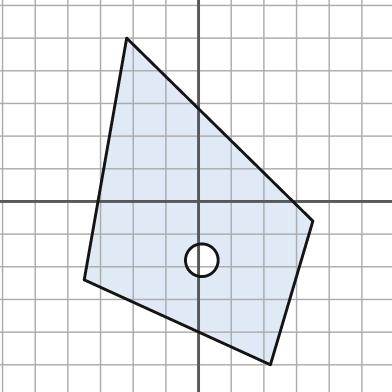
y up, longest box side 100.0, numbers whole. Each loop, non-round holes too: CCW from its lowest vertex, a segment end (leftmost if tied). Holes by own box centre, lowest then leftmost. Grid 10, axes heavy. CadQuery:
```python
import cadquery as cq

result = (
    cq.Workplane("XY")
    .moveTo(22.0, -50.0)
    .lineTo(35.0, -6.0)
    .lineTo(-22.0, 50.0)
    .lineTo(-35.0, -24.0)
    .close()
    .moveTo(1.0, -18.0)
    .circle(5.0)
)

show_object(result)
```